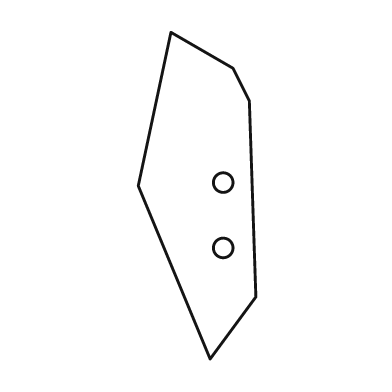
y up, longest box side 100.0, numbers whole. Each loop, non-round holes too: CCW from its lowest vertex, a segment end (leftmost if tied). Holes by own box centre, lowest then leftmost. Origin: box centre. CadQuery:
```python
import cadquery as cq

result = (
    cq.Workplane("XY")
    .moveTo(4.0, -50.0)
    .lineTo(18.0, -31.0)
    .lineTo(16.0, 29.0)
    .lineTo(11.0, 39.0)
    .lineTo(-8.0, 50.0)
    .lineTo(-18.0, 3.0)
    .close()
    .moveTo(8.0, -16.0)
    .circle(3.0)
    .moveTo(8.0, 4.0)
    .circle(3.0)
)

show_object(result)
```